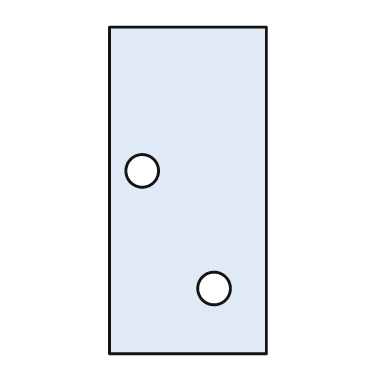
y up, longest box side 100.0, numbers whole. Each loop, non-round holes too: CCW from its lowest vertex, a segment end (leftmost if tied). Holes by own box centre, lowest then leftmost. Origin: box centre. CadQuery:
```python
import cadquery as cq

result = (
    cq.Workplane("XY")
    .moveTo(-24.0, -50.0)
    .lineTo(24.0, -50.0)
    .lineTo(24.0, 50.0)
    .lineTo(-24.0, 50.0)
    .close()
    .moveTo(8.0, -30.0)
    .circle(5.0)
    .moveTo(-14.0, 6.0)
    .circle(5.0)
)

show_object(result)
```